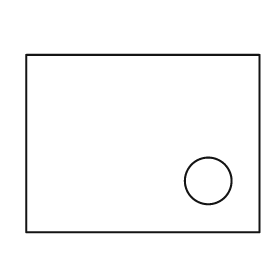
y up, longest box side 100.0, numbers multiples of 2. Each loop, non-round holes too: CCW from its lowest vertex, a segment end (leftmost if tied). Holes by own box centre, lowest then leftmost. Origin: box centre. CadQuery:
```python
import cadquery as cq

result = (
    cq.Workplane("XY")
    .moveTo(-50.0, -38.0)
    .lineTo(50.0, -38.0)
    .lineTo(50.0, 38.0)
    .lineTo(-50.0, 38.0)
    .close()
    .moveTo(28.0, -16.0)
    .circle(10.0)
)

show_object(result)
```